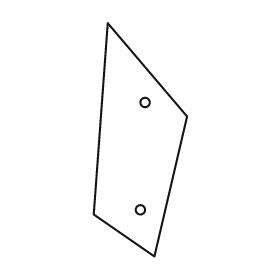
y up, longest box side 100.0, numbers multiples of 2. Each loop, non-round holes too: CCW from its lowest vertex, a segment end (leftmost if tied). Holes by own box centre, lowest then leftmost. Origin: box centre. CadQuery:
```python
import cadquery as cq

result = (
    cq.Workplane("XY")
    .moveTo(6.0, -50.0)
    .lineTo(20.0, 10.0)
    .lineTo(-14.0, 50.0)
    .lineTo(-20.0, -32.0)
    .close()
    .moveTo(0.0, -30.0)
    .circle(2.0)
    .moveTo(2.0, 16.0)
    .circle(2.0)
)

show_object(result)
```